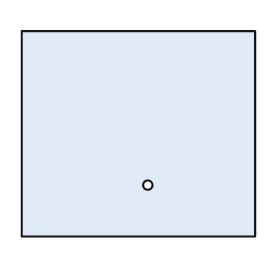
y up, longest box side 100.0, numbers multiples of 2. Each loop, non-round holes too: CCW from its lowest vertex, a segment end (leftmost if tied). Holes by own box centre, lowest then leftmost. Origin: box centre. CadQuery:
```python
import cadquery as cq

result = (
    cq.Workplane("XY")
    .moveTo(-50.0, -44.0)
    .lineTo(50.0, -44.0)
    .lineTo(50.0, 44.0)
    .lineTo(-50.0, 44.0)
    .close()
    .moveTo(4.0, -22.0)
    .circle(2.0)
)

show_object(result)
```